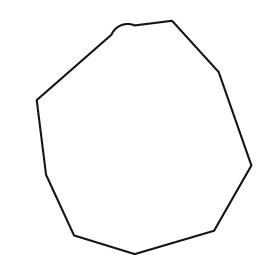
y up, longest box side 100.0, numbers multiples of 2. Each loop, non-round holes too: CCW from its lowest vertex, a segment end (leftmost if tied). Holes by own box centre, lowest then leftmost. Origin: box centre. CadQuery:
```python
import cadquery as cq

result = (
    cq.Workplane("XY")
    .moveTo(-4.0, -50.0)
    .lineTo(30.0, -40.0)
    .lineTo(46.0, -12.0)
    .lineTo(32.0, 28.0)
    .lineTo(12.0, 50.0)
    .lineTo(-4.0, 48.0)
    .threePointArc((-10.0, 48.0), (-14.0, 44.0))
    .lineTo(-46.0, 16.0)
    .lineTo(-42.0, -16.0)
    .lineTo(-30.0, -42.0)
    .close()
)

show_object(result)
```